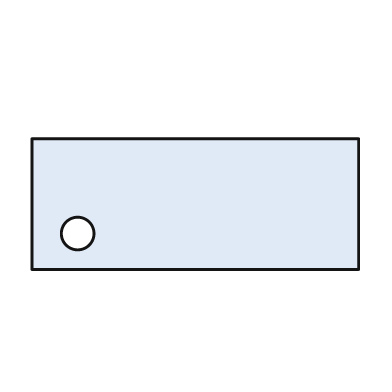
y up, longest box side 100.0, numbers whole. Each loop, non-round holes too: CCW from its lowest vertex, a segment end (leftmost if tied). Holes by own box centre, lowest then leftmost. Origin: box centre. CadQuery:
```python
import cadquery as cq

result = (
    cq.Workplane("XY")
    .moveTo(-50.0, -20.0)
    .lineTo(50.0, -20.0)
    .lineTo(50.0, 20.0)
    .lineTo(-50.0, 20.0)
    .close()
    .moveTo(-36.0, -9.0)
    .circle(5.0)
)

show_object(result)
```